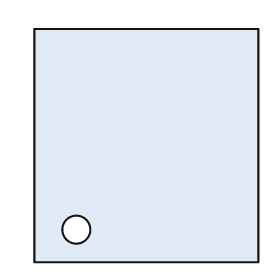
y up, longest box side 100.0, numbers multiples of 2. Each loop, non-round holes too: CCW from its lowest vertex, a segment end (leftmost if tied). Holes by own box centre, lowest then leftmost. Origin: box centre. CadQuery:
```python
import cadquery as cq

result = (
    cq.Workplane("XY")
    .moveTo(-48.0, -50.0)
    .lineTo(48.0, -50.0)
    .lineTo(48.0, 50.0)
    .lineTo(-48.0, 50.0)
    .close()
    .moveTo(-30.0, -36.0)
    .circle(6.0)
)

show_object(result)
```